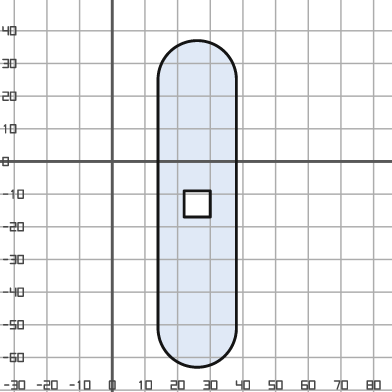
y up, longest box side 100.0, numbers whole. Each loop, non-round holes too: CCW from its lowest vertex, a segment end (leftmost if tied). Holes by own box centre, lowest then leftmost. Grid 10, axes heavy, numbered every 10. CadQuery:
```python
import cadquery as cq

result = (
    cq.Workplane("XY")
    .moveTo(14.0, -51.0)
    .threePointArc((26.0, -63.0), (38.0, -51.0))
    .lineTo(38.0, 25.0)
    .threePointArc((26.0, 37.0), (14.0, 25.0))
    .close()
    .moveTo(22.0, -17.0)
    .lineTo(30.0, -17.0)
    .lineTo(30.0, -9.0)
    .lineTo(22.0, -9.0)
    .close()
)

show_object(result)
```